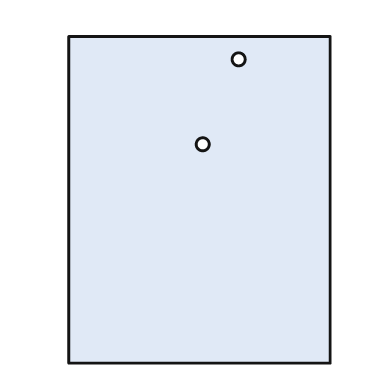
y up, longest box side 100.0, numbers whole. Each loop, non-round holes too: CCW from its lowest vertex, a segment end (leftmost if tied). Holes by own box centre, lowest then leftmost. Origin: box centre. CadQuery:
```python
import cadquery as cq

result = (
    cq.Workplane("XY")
    .moveTo(-40.0, -50.0)
    .lineTo(40.0, -50.0)
    .lineTo(40.0, 50.0)
    .lineTo(-40.0, 50.0)
    .close()
    .moveTo(1.0, 17.0)
    .circle(2.0)
    .moveTo(12.0, 43.0)
    .circle(2.0)
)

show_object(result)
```